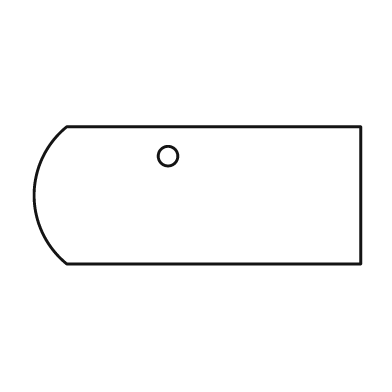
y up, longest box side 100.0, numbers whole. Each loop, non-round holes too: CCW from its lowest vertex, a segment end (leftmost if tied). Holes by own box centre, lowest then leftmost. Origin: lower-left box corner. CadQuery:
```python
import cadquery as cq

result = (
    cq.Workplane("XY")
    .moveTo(10.0, 0.0)
    .lineTo(100.0, 0.0)
    .lineTo(100.0, 42.0)
    .lineTo(10.0, 42.0)
    .threePointArc((0.0, 21.0), (10.0, 0.0))
    .close()
    .moveTo(41.0, 33.0)
    .circle(3.0)
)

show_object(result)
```